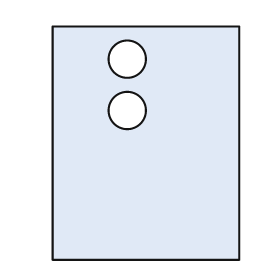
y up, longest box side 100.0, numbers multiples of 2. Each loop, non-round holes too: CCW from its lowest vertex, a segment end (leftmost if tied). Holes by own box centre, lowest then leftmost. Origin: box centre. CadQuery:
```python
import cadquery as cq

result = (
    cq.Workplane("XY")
    .moveTo(-40.0, -50.0)
    .lineTo(40.0, -50.0)
    .lineTo(40.0, 50.0)
    .lineTo(-40.0, 50.0)
    .close()
    .moveTo(-8.0, 14.0)
    .circle(8.0)
    .moveTo(-8.0, 36.0)
    .circle(8.0)
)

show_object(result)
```